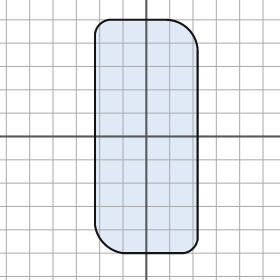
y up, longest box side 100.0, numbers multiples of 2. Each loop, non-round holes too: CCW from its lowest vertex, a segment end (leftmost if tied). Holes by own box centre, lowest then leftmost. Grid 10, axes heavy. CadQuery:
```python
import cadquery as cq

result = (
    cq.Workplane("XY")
    .moveTo(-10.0, -50.0)
    .lineTo(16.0, -50.0)
    .threePointArc((20.0, -48.0), (22.0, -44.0))
    .lineTo(22.0, 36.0)
    .threePointArc((18.0, 46.0), (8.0, 50.0))
    .lineTo(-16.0, 50.0)
    .threePointArc((-20.0, 48.0), (-22.0, 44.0))
    .lineTo(-22.0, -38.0)
    .threePointArc((-18.0, -46.0), (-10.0, -50.0))
    .close()
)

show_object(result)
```